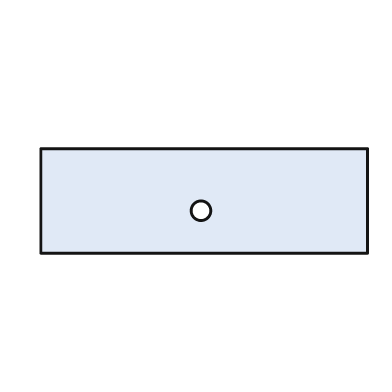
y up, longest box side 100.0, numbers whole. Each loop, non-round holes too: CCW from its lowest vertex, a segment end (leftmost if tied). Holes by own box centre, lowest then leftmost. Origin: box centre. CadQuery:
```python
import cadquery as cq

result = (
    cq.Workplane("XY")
    .moveTo(-50.0, -16.0)
    .lineTo(50.0, -16.0)
    .lineTo(50.0, 16.0)
    .lineTo(-50.0, 16.0)
    .close()
    .moveTo(-1.0, -3.0)
    .circle(3.0)
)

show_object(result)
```